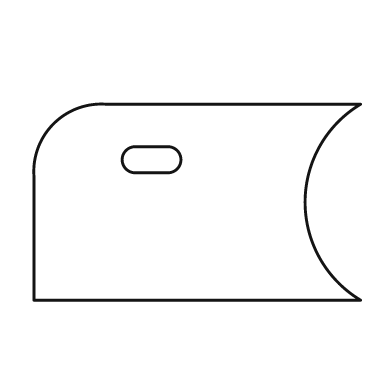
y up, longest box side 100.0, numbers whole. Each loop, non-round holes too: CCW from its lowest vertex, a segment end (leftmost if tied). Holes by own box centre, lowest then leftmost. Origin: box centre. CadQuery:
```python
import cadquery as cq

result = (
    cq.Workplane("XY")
    .moveTo(-50.0, -30.0)
    .lineTo(50.0, -30.0)
    .threePointArc((33.0, 0.0), (50.0, 30.0))
    .lineTo(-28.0, 30.0)
    .threePointArc((-44.0, 24.0), (-50.0, 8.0))
    .close()
    .moveTo(-19.0, 9.0)
    .lineTo(-9.0, 9.0)
    .threePointArc((-5.0, 13.0), (-9.0, 17.0))
    .lineTo(-19.0, 17.0)
    .threePointArc((-23.0, 13.0), (-19.0, 9.0))
    .close()
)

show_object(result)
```